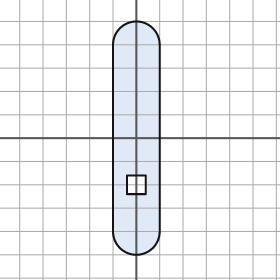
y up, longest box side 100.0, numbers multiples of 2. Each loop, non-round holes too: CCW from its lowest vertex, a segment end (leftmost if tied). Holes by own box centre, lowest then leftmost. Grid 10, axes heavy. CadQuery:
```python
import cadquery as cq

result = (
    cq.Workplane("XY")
    .moveTo(-10.0, -40.0)
    .threePointArc((0.0, -50.0), (10.0, -40.0))
    .lineTo(10.0, 40.0)
    .threePointArc((0.0, 50.0), (-10.0, 40.0))
    .close()
    .moveTo(-4.0, -24.0)
    .lineTo(4.0, -24.0)
    .lineTo(4.0, -16.0)
    .lineTo(-4.0, -16.0)
    .close()
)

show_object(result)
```